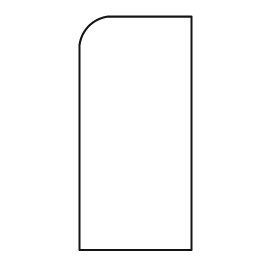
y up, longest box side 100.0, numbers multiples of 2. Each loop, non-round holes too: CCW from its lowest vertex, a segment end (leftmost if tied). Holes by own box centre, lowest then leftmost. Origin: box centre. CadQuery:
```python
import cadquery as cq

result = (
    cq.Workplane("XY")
    .moveTo(-24.0, -50.0)
    .lineTo(24.0, -50.0)
    .lineTo(24.0, 50.0)
    .lineTo(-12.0, 50.0)
    .threePointArc((-20.0, 46.0), (-24.0, 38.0))
    .close()
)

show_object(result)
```